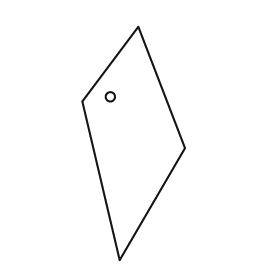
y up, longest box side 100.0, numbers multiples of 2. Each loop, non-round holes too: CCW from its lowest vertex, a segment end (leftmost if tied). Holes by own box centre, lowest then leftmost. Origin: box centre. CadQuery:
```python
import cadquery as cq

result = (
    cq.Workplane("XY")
    .moveTo(-6.0, -50.0)
    .lineTo(22.0, -2.0)
    .lineTo(2.0, 50.0)
    .lineTo(-22.0, 18.0)
    .close()
    .moveTo(-10.0, 20.0)
    .circle(2.0)
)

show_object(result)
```